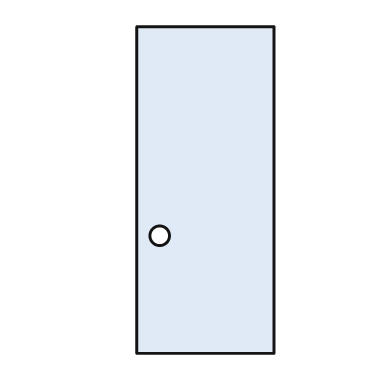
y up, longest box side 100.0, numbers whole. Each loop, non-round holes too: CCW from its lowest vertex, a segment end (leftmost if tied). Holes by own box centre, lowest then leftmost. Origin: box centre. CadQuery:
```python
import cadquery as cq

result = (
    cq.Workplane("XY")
    .moveTo(-21.0, -50.0)
    .lineTo(21.0, -50.0)
    .lineTo(21.0, 50.0)
    .lineTo(-21.0, 50.0)
    .close()
    .moveTo(-14.0, -14.0)
    .circle(3.0)
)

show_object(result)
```